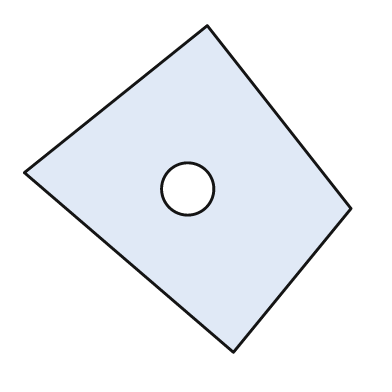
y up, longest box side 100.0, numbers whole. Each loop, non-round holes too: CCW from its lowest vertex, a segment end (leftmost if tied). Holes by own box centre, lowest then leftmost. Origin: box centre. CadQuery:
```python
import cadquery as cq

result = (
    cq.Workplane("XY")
    .moveTo(14.0, -50.0)
    .lineTo(50.0, -6.0)
    .lineTo(6.0, 50.0)
    .lineTo(-50.0, 5.0)
    .close()
    .moveTo(0.0, 0.0)
    .circle(8.0)
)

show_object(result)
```